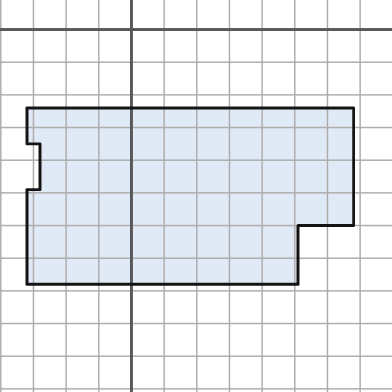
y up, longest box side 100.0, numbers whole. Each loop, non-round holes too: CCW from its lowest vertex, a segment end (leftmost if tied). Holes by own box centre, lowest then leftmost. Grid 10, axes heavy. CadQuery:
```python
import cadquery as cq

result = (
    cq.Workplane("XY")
    .moveTo(-32.0, -78.0)
    .lineTo(51.0, -78.0)
    .lineTo(51.0, -60.0)
    .lineTo(68.0, -60.0)
    .lineTo(68.0, -24.0)
    .lineTo(-32.0, -24.0)
    .lineTo(-32.0, -35.0)
    .lineTo(-28.0, -35.0)
    .lineTo(-28.0, -49.0)
    .lineTo(-32.0, -49.0)
    .close()
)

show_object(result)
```